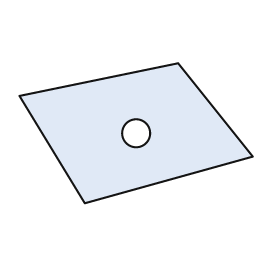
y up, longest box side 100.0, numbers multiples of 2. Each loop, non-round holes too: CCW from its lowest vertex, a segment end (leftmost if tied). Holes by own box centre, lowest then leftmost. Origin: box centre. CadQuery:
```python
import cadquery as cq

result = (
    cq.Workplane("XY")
    .moveTo(-22.0, -30.0)
    .lineTo(50.0, -10.0)
    .lineTo(18.0, 30.0)
    .lineTo(-50.0, 16.0)
    .close()
    .moveTo(0.0, 0.0)
    .circle(6.0)
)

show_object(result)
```